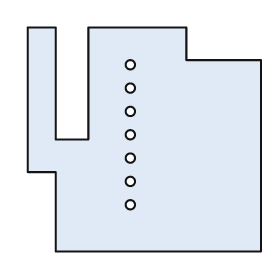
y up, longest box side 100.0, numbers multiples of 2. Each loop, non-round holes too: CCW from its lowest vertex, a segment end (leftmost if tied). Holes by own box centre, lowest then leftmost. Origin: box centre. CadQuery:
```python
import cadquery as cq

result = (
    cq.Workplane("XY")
    .moveTo(-38.0, -48.0)
    .lineTo(50.0, -48.0)
    .lineTo(50.0, 34.0)
    .lineTo(18.0, 34.0)
    .lineTo(18.0, 48.0)
    .lineTo(-24.0, 48.0)
    .lineTo(-24.0, 0.0)
    .lineTo(-38.0, 0.0)
    .lineTo(-38.0, 48.0)
    .lineTo(-50.0, 48.0)
    .lineTo(-50.0, -14.0)
    .lineTo(-38.0, -14.0)
    .close()
    .moveTo(-6.0, -28.0)
    .circle(2.0)
    .moveTo(-6.0, -18.0)
    .circle(2.0)
    .moveTo(-6.0, -8.0)
    .circle(2.0)
    .moveTo(-6.0, 2.0)
    .circle(2.0)
    .moveTo(-6.0, 12.0)
    .circle(2.0)
    .moveTo(-6.0, 22.0)
    .circle(2.0)
    .moveTo(-6.0, 32.0)
    .circle(2.0)
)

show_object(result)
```